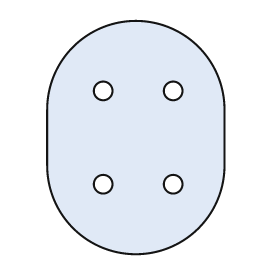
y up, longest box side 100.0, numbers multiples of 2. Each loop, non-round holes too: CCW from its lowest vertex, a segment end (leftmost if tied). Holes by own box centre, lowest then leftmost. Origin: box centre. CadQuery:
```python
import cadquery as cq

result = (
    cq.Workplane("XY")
    .moveTo(-38.0, -12.0)
    .threePointArc((0.0, -50.0), (38.0, -12.0))
    .lineTo(38.0, 12.0)
    .threePointArc((0.0, 50.0), (-38.0, 12.0))
    .close()
    .moveTo(-14.0, -20.0)
    .circle(4.0)
    .moveTo(16.0, -20.0)
    .circle(4.0)
    .moveTo(-14.0, 20.0)
    .circle(4.0)
    .moveTo(16.0, 20.0)
    .circle(4.0)
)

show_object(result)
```